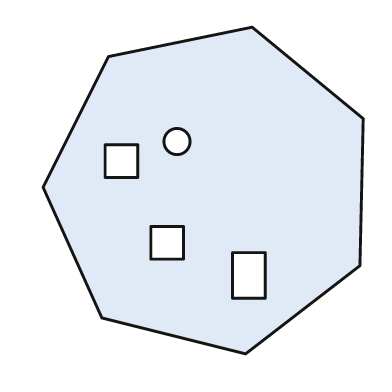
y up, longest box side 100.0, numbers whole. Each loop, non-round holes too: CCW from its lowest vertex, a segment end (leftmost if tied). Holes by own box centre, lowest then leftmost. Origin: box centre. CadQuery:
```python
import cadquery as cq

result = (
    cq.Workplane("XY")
    .moveTo(13.0, -50.0)
    .lineTo(48.0, -23.0)
    .lineTo(49.0, 22.0)
    .lineTo(15.0, 50.0)
    .lineTo(-29.0, 41.0)
    .lineTo(-49.0, 1.0)
    .lineTo(-31.0, -39.0)
    .close()
    .moveTo(9.0, -33.0)
    .lineTo(19.0, -33.0)
    .lineTo(19.0, -19.0)
    .lineTo(9.0, -19.0)
    .close()
    .moveTo(-16.0, -21.0)
    .lineTo(-6.0, -21.0)
    .lineTo(-6.0, -11.0)
    .lineTo(-16.0, -11.0)
    .close()
    .moveTo(-30.0, 4.0)
    .lineTo(-20.0, 4.0)
    .lineTo(-20.0, 14.0)
    .lineTo(-30.0, 14.0)
    .close()
    .moveTo(-8.0, 15.0)
    .circle(4.0)
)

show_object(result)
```